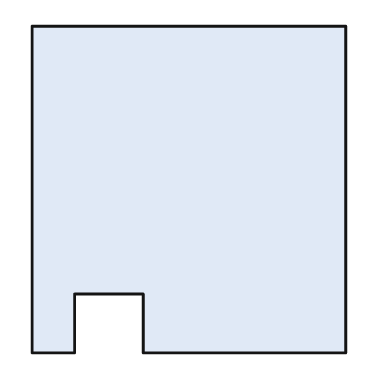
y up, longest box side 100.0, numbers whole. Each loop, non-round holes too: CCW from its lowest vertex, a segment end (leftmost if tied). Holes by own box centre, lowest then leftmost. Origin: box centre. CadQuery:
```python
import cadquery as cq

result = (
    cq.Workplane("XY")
    .moveTo(-48.0, -50.0)
    .lineTo(-35.0, -50.0)
    .lineTo(-35.0, -32.0)
    .lineTo(-14.0, -32.0)
    .lineTo(-14.0, -50.0)
    .lineTo(48.0, -50.0)
    .lineTo(48.0, 50.0)
    .lineTo(-48.0, 50.0)
    .close()
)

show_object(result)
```